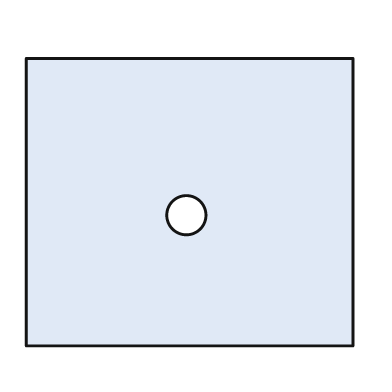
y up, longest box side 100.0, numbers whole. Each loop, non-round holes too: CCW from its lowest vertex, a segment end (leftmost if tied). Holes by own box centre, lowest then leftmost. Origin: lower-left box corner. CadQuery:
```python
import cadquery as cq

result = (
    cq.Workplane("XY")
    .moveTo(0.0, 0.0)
    .lineTo(100.0, 0.0)
    .lineTo(100.0, 88.0)
    .lineTo(0.0, 88.0)
    .close()
    .moveTo(49.0, 40.0)
    .circle(6.0)
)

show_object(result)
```